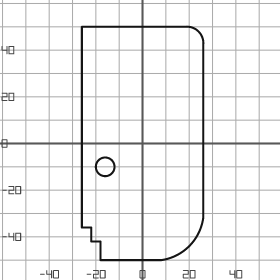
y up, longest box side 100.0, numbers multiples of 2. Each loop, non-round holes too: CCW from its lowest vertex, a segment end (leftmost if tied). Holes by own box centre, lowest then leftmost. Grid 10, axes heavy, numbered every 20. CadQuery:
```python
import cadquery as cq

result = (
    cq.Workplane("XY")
    .moveTo(-18.0, -50.0)
    .lineTo(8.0, -50.0)
    .threePointArc((20.0, -44.0), (26.0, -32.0))
    .lineTo(26.0, 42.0)
    .threePointArc((24.0, 48.0), (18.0, 50.0))
    .lineTo(-26.0, 50.0)
    .lineTo(-26.0, -36.0)
    .lineTo(-22.0, -36.0)
    .lineTo(-22.0, -42.0)
    .lineTo(-18.0, -42.0)
    .close()
    .moveTo(-16.0, -10.0)
    .circle(4.0)
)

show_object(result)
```